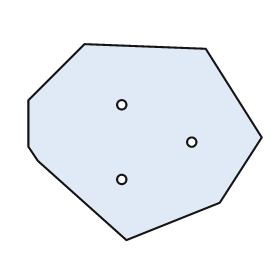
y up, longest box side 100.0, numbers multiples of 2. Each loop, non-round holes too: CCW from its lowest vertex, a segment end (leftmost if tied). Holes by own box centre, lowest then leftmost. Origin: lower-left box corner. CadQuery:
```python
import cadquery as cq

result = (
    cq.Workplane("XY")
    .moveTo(42.0, 0.0)
    .lineTo(82.0, 16.0)
    .lineTo(100.0, 44.0)
    .lineTo(76.0, 82.0)
    .lineTo(24.0, 84.0)
    .lineTo(0.0, 60.0)
    .lineTo(0.0, 40.0)
    .lineTo(4.0, 34.0)
    .close()
    .moveTo(40.0, 26.0)
    .circle(2.0)
    .moveTo(70.0, 42.0)
    .circle(2.0)
    .moveTo(40.0, 58.0)
    .circle(2.0)
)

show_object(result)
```